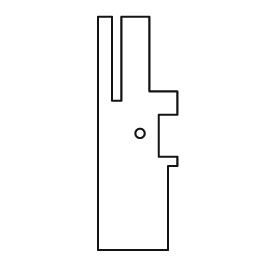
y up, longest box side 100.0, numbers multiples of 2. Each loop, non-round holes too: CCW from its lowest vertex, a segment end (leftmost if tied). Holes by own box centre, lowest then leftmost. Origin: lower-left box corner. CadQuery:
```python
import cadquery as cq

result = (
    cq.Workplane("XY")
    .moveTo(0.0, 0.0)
    .lineTo(30.0, 0.0)
    .lineTo(30.0, 36.0)
    .lineTo(34.0, 36.0)
    .lineTo(34.0, 40.0)
    .lineTo(26.0, 40.0)
    .lineTo(26.0, 58.0)
    .lineTo(34.0, 58.0)
    .lineTo(34.0, 68.0)
    .lineTo(22.0, 68.0)
    .lineTo(22.0, 100.0)
    .lineTo(10.0, 100.0)
    .lineTo(10.0, 64.0)
    .lineTo(6.0, 64.0)
    .lineTo(6.0, 100.0)
    .lineTo(0.0, 100.0)
    .close()
    .moveTo(18.0, 50.0)
    .circle(2.0)
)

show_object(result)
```